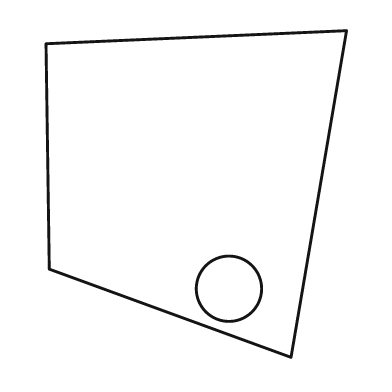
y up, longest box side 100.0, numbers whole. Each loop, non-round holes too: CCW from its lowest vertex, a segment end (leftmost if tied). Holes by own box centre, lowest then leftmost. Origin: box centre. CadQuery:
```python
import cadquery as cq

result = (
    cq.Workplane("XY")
    .moveTo(29.0, -50.0)
    .lineTo(46.0, 50.0)
    .lineTo(-46.0, 46.0)
    .lineTo(-45.0, -23.0)
    .close()
    .moveTo(10.0, -29.0)
    .circle(10.0)
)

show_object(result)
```